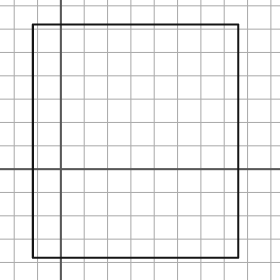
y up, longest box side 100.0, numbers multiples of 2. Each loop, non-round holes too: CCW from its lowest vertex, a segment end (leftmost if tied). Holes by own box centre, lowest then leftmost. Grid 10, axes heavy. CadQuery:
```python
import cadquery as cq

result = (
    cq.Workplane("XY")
    .moveTo(-12.0, -38.0)
    .lineTo(76.0, -38.0)
    .lineTo(76.0, 62.0)
    .lineTo(-12.0, 62.0)
    .close()
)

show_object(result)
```